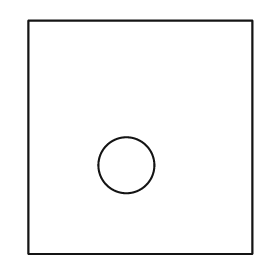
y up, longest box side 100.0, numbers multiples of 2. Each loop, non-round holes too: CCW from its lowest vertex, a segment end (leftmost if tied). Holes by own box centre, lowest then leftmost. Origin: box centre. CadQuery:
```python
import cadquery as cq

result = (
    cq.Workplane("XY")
    .moveTo(-48.0, -50.0)
    .lineTo(48.0, -50.0)
    .lineTo(48.0, 50.0)
    .lineTo(-48.0, 50.0)
    .close()
    .moveTo(-6.0, -12.0)
    .circle(12.0)
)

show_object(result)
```